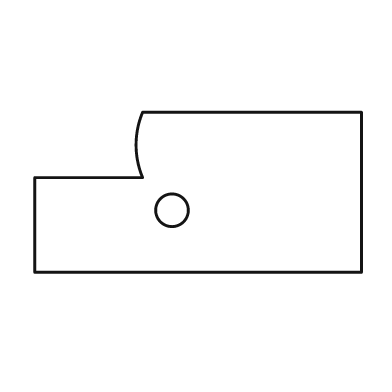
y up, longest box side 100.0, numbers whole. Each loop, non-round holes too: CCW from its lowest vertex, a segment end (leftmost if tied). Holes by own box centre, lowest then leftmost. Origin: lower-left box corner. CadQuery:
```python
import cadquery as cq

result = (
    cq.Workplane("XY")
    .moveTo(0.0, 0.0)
    .lineTo(100.0, 0.0)
    .lineTo(100.0, 49.0)
    .lineTo(33.0, 49.0)
    .threePointArc((31.0, 39.0), (33.0, 29.0))
    .lineTo(0.0, 29.0)
    .close()
    .moveTo(42.0, 19.0)
    .circle(5.0)
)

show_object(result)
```